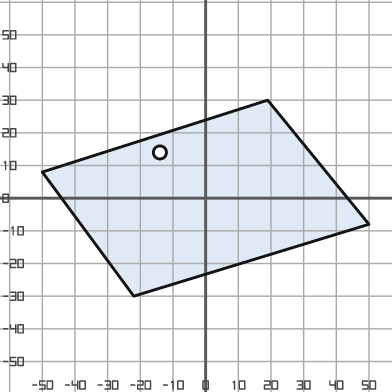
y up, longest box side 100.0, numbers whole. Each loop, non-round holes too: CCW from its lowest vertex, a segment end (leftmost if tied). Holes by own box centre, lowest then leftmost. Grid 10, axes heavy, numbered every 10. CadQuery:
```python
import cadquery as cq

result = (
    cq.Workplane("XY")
    .moveTo(-22.0, -30.0)
    .lineTo(50.0, -8.0)
    .lineTo(19.0, 30.0)
    .lineTo(-50.0, 8.0)
    .close()
    .moveTo(-14.0, 14.0)
    .circle(2.0)
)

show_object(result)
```